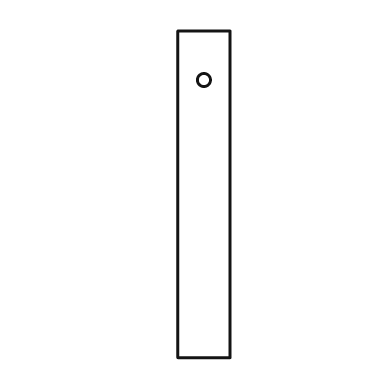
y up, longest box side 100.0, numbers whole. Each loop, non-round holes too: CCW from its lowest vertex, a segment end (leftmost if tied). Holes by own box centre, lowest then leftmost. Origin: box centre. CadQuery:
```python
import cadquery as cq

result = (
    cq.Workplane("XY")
    .moveTo(-8.0, -50.0)
    .lineTo(8.0, -50.0)
    .lineTo(8.0, 50.0)
    .lineTo(-8.0, 50.0)
    .close()
    .moveTo(0.0, 35.0)
    .circle(2.0)
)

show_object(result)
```